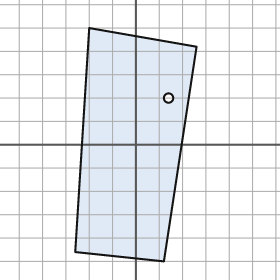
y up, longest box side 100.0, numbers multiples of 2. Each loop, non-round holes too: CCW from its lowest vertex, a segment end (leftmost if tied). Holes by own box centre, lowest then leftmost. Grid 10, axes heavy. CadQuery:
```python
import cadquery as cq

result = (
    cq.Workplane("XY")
    .moveTo(12.0, -50.0)
    .lineTo(26.0, 42.0)
    .lineTo(-20.0, 50.0)
    .lineTo(-26.0, -46.0)
    .close()
    .moveTo(14.0, 20.0)
    .circle(2.0)
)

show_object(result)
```